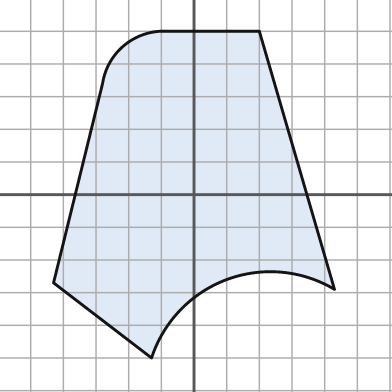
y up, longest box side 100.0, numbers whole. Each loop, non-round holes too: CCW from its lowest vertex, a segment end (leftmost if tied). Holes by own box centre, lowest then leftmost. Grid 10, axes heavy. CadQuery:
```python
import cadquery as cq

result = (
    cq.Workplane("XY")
    .moveTo(-13.0, -50.0)
    .threePointArc((10.0, -26.0), (43.0, -29.0))
    .lineTo(20.0, 50.0)
    .lineTo(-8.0, 50.0)
    .threePointArc((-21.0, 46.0), (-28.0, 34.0))
    .lineTo(-43.0, -27.0)
    .close()
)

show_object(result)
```